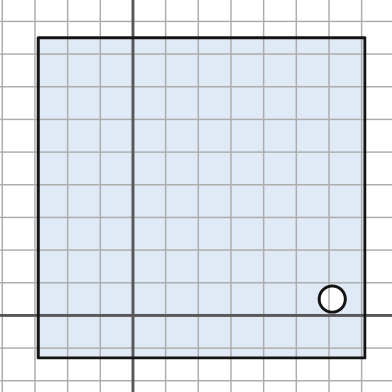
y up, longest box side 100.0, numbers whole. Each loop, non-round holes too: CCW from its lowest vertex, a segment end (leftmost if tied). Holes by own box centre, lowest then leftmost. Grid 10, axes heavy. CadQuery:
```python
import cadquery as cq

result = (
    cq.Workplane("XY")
    .moveTo(-29.0, -13.0)
    .lineTo(71.0, -13.0)
    .lineTo(71.0, 85.0)
    .lineTo(-29.0, 85.0)
    .close()
    .moveTo(61.0, 5.0)
    .circle(4.0)
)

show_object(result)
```